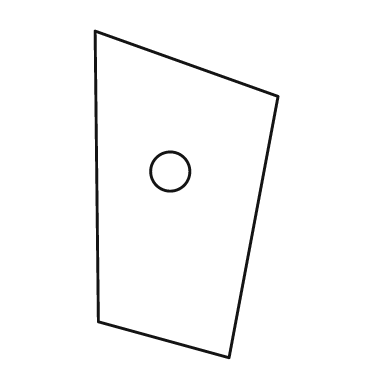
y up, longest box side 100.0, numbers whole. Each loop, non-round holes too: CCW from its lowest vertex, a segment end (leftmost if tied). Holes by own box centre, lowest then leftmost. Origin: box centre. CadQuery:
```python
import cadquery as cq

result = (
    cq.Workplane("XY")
    .moveTo(13.0, -50.0)
    .lineTo(28.0, 30.0)
    .lineTo(-28.0, 50.0)
    .lineTo(-27.0, -39.0)
    .close()
    .moveTo(-5.0, 7.0)
    .circle(6.0)
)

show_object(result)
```